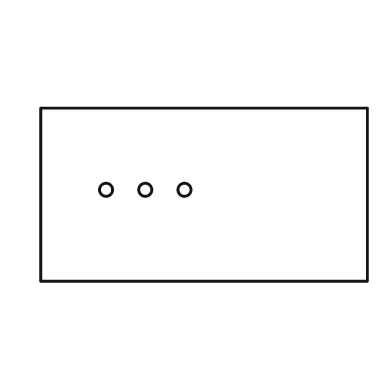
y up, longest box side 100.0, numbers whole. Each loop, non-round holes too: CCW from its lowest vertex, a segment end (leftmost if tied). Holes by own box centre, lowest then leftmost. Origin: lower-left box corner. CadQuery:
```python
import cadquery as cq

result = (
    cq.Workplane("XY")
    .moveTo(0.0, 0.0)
    .lineTo(100.0, 0.0)
    .lineTo(100.0, 53.0)
    .lineTo(0.0, 53.0)
    .close()
    .moveTo(20.0, 28.0)
    .circle(2.0)
    .moveTo(32.0, 28.0)
    .circle(2.0)
    .moveTo(44.0, 28.0)
    .circle(2.0)
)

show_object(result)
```